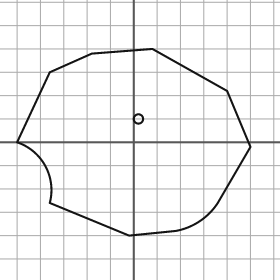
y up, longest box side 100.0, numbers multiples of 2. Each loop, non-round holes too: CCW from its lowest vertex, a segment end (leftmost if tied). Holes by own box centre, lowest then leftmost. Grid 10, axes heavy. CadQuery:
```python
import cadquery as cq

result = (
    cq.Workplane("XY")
    .moveTo(-2.0, -40.0)
    .lineTo(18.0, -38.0)
    .threePointArc((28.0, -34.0), (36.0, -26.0))
    .lineTo(50.0, -2.0)
    .lineTo(40.0, 22.0)
    .lineTo(8.0, 40.0)
    .lineTo(-18.0, 38.0)
    .lineTo(-36.0, 30.0)
    .lineTo(-50.0, 0.0)
    .threePointArc((-38.0, -10.0), (-36.0, -26.0))
    .close()
    .moveTo(2.0, 10.0)
    .circle(2.0)
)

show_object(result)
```